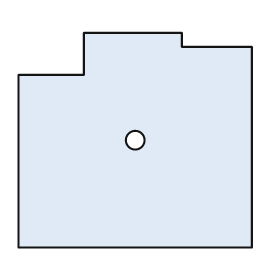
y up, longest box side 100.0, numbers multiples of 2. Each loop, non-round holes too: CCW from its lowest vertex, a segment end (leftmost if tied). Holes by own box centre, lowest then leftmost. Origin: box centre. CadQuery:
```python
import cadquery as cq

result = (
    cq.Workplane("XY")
    .moveTo(-50.0, -46.0)
    .lineTo(50.0, -46.0)
    .lineTo(50.0, 40.0)
    .lineTo(20.0, 40.0)
    .lineTo(20.0, 46.0)
    .lineTo(-22.0, 46.0)
    .lineTo(-22.0, 28.0)
    .lineTo(-50.0, 28.0)
    .close()
    .moveTo(0.0, 0.0)
    .circle(4.0)
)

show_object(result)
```